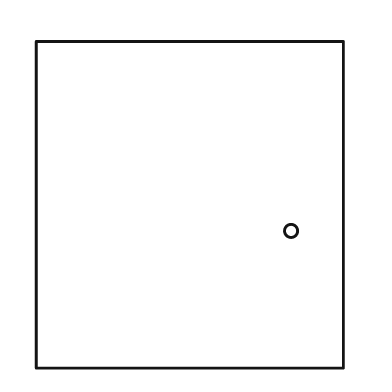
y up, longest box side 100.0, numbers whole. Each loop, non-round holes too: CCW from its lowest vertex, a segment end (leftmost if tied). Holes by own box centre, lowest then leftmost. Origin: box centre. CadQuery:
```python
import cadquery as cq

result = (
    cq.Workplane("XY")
    .moveTo(-47.0, -50.0)
    .lineTo(47.0, -50.0)
    .lineTo(47.0, 50.0)
    .lineTo(-47.0, 50.0)
    .close()
    .moveTo(31.0, -8.0)
    .circle(2.0)
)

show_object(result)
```